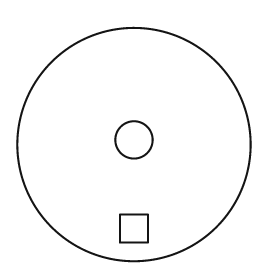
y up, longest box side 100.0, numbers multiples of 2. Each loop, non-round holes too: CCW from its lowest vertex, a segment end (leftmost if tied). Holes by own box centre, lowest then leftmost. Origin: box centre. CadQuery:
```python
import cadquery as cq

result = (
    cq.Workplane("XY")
    .moveTo(0.0, 0.0)
    .circle(50.0)
    .moveTo(-6.0, -42.0)
    .lineTo(6.0, -42.0)
    .lineTo(6.0, -30.0)
    .lineTo(-6.0, -30.0)
    .close()
    .moveTo(0.0, 2.0)
    .circle(8.0)
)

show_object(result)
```